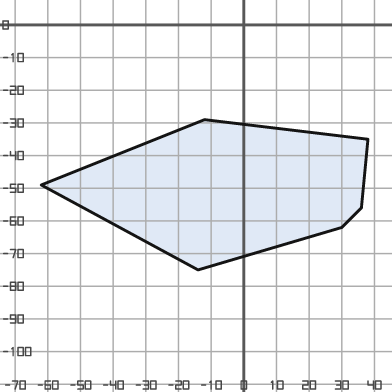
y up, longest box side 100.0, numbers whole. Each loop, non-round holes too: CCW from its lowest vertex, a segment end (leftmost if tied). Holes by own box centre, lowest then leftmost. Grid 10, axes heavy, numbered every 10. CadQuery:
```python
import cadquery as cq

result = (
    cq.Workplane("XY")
    .moveTo(-14.0, -75.0)
    .lineTo(30.0, -62.0)
    .lineTo(36.0, -56.0)
    .lineTo(38.0, -35.0)
    .lineTo(-12.0, -29.0)
    .lineTo(-62.0, -49.0)
    .close()
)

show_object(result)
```